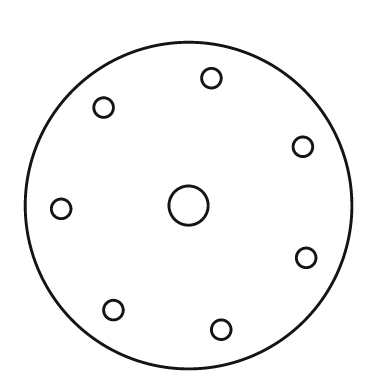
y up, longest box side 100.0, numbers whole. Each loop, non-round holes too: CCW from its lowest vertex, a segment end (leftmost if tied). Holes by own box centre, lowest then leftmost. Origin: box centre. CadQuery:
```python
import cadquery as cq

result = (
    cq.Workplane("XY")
    .moveTo(0.0, 0.0)
    .circle(50.0)
    .moveTo(10.0, -38.0)
    .circle(3.0)
    .moveTo(-23.0, -32.0)
    .circle(3.0)
    .moveTo(36.0, -16.0)
    .circle(3.0)
    .moveTo(-39.0, -1.0)
    .circle(3.0)
    .moveTo(0.0, 0.0)
    .circle(6.0)
    .moveTo(35.0, 18.0)
    .circle(3.0)
    .moveTo(-26.0, 30.0)
    .circle(3.0)
    .moveTo(7.0, 39.0)
    .circle(3.0)
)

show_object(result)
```